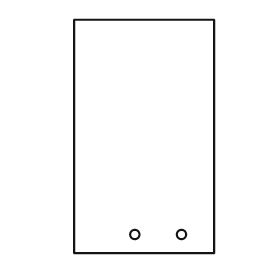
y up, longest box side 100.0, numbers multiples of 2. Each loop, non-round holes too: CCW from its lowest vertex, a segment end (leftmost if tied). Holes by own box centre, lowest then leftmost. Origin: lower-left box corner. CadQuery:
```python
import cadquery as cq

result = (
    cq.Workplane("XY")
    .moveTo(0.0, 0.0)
    .lineTo(60.0, 0.0)
    .lineTo(60.0, 100.0)
    .lineTo(0.0, 100.0)
    .close()
    .moveTo(26.0, 8.0)
    .circle(2.0)
    .moveTo(46.0, 8.0)
    .circle(2.0)
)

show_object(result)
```